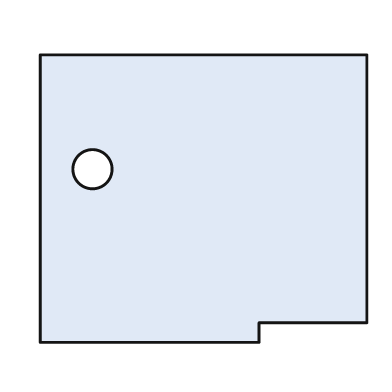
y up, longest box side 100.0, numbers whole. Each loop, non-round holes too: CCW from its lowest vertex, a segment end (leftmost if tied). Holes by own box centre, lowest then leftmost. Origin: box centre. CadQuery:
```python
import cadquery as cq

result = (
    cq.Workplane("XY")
    .moveTo(-50.0, -44.0)
    .lineTo(17.0, -44.0)
    .lineTo(17.0, -38.0)
    .lineTo(50.0, -38.0)
    .lineTo(50.0, 44.0)
    .lineTo(-50.0, 44.0)
    .close()
    .moveTo(-34.0, 9.0)
    .circle(6.0)
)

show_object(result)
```